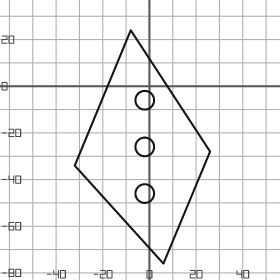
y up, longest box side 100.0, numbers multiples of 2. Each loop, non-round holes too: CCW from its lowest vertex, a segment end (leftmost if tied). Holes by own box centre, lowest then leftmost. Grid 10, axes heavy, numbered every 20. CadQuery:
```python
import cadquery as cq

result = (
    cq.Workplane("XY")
    .moveTo(6.0, -76.0)
    .lineTo(26.0, -28.0)
    .lineTo(-8.0, 24.0)
    .lineTo(-32.0, -34.0)
    .close()
    .moveTo(-2.0, -46.0)
    .circle(4.0)
    .moveTo(-2.0, -26.0)
    .circle(4.0)
    .moveTo(-2.0, -6.0)
    .circle(4.0)
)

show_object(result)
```